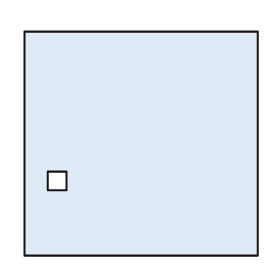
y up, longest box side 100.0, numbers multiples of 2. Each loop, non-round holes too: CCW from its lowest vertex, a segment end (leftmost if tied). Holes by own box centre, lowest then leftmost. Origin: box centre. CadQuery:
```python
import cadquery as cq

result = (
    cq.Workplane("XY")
    .moveTo(-50.0, -48.0)
    .lineTo(50.0, -48.0)
    .lineTo(50.0, 48.0)
    .lineTo(-50.0, 48.0)
    .close()
    .moveTo(-40.0, -20.0)
    .lineTo(-32.0, -20.0)
    .lineTo(-32.0, -12.0)
    .lineTo(-40.0, -12.0)
    .close()
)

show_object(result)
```